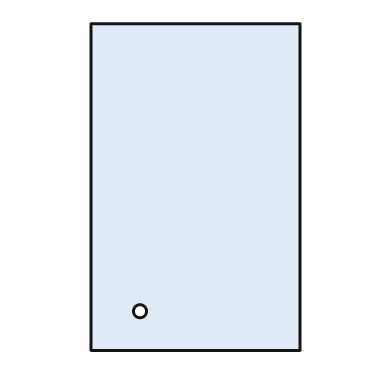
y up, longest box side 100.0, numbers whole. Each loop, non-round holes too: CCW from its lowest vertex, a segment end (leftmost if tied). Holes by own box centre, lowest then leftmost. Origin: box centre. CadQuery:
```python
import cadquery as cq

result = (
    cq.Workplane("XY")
    .moveTo(-32.0, -50.0)
    .lineTo(32.0, -50.0)
    .lineTo(32.0, 50.0)
    .lineTo(-32.0, 50.0)
    .close()
    .moveTo(-17.0, -38.0)
    .circle(2.0)
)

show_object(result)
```